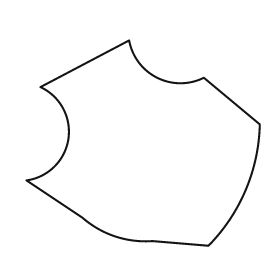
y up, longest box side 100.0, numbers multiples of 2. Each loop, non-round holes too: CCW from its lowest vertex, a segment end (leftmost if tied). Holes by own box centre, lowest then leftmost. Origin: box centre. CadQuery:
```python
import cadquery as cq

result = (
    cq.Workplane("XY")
    .moveTo(28.0, -44.0)
    .threePointArc((44.0, -20.0), (50.0, 8.0))
    .lineTo(26.0, 28.0)
    .threePointArc((6.0, 28.0), (-6.0, 44.0))
    .lineTo(-44.0, 24.0)
    .threePointArc((-32.0, 2.0), (-50.0, -16.0))
    .lineTo(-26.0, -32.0)
    .threePointArc((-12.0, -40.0), (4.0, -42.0))
    .close()
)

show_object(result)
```